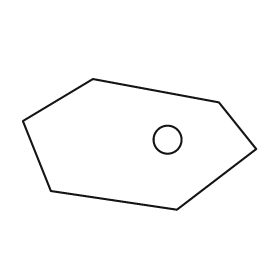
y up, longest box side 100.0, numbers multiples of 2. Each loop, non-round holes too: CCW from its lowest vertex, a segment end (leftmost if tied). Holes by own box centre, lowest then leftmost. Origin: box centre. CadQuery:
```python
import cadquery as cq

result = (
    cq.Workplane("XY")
    .moveTo(16.0, -28.0)
    .lineTo(50.0, -2.0)
    .lineTo(34.0, 18.0)
    .lineTo(-20.0, 28.0)
    .lineTo(-50.0, 10.0)
    .lineTo(-38.0, -20.0)
    .close()
    .moveTo(12.0, 2.0)
    .circle(6.0)
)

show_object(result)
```